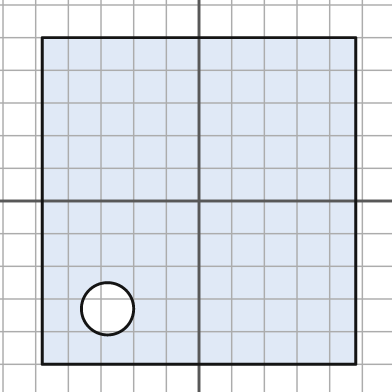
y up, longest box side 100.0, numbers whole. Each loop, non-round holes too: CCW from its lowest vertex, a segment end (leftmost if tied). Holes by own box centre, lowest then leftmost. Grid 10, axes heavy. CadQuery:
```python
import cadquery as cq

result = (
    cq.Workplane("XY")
    .moveTo(-48.0, -50.0)
    .lineTo(48.0, -50.0)
    .lineTo(48.0, 50.0)
    .lineTo(-48.0, 50.0)
    .close()
    .moveTo(-28.0, -33.0)
    .circle(8.0)
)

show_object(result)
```